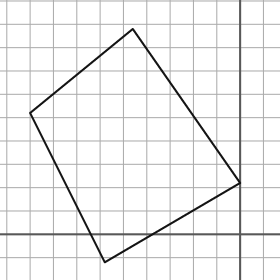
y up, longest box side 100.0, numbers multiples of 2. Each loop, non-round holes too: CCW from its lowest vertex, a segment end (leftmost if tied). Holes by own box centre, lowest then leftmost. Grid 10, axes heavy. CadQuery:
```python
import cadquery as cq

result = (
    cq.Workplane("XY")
    .moveTo(-58.0, -12.0)
    .lineTo(0.0, 22.0)
    .lineTo(-46.0, 88.0)
    .lineTo(-90.0, 52.0)
    .close()
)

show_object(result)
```